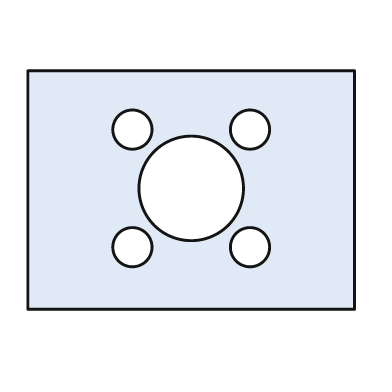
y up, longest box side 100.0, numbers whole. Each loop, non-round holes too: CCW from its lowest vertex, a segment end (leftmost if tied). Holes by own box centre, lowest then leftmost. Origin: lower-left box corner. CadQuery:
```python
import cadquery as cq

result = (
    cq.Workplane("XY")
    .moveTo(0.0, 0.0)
    .lineTo(100.0, 0.0)
    .lineTo(100.0, 73.0)
    .lineTo(0.0, 73.0)
    .close()
    .moveTo(32.0, 19.0)
    .circle(6.0)
    .moveTo(68.0, 19.0)
    .circle(6.0)
    .moveTo(50.0, 37.0)
    .circle(16.0)
    .moveTo(32.0, 55.0)
    .circle(6.0)
    .moveTo(68.0, 55.0)
    .circle(6.0)
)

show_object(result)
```